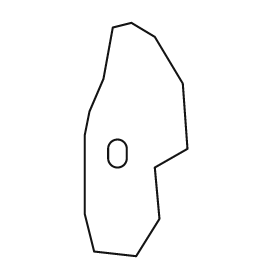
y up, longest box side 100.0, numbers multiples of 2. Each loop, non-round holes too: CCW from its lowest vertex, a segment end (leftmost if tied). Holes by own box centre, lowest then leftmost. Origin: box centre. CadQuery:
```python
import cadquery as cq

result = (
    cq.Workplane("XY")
    .moveTo(0.0, -50.0)
    .lineTo(10.0, -34.0)
    .lineTo(8.0, -12.0)
    .lineTo(22.0, -4.0)
    .lineTo(20.0, 24.0)
    .lineTo(8.0, 44.0)
    .lineTo(-2.0, 50.0)
    .lineTo(-10.0, 48.0)
    .lineTo(-14.0, 26.0)
    .lineTo(-20.0, 12.0)
    .lineTo(-22.0, 2.0)
    .lineTo(-22.0, -32.0)
    .lineTo(-18.0, -48.0)
    .close()
    .moveTo(-12.0, -8.0)
    .threePointArc((-8.0, -12.0), (-4.0, -8.0))
    .lineTo(-4.0, -4.0)
    .threePointArc((-8.0, 0.0), (-12.0, -4.0))
    .close()
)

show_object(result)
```